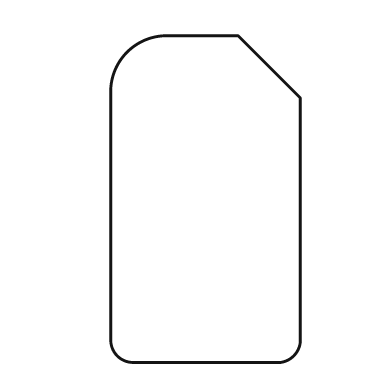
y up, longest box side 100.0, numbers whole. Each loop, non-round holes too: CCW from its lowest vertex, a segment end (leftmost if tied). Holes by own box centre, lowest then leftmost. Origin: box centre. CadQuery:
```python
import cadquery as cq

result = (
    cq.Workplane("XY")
    .moveTo(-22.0, -50.0)
    .lineTo(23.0, -50.0)
    .threePointArc((27.0, -48.0), (29.0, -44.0))
    .lineTo(29.0, 31.0)
    .lineTo(10.0, 50.0)
    .lineTo(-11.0, 50.0)
    .threePointArc((-24.0, 45.0), (-29.0, 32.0))
    .lineTo(-29.0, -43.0)
    .threePointArc((-27.0, -48.0), (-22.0, -50.0))
    .close()
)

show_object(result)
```